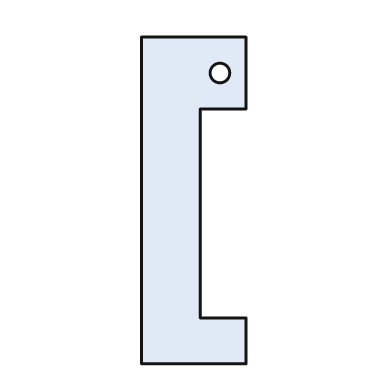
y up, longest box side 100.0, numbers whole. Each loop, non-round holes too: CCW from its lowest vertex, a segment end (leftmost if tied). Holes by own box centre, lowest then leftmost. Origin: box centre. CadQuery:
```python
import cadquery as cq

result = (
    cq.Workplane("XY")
    .moveTo(-16.0, -50.0)
    .lineTo(16.0, -50.0)
    .lineTo(16.0, -36.0)
    .lineTo(2.0, -36.0)
    .lineTo(2.0, 28.0)
    .lineTo(16.0, 28.0)
    .lineTo(16.0, 50.0)
    .lineTo(-16.0, 50.0)
    .close()
    .moveTo(8.0, 39.0)
    .circle(3.0)
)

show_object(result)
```